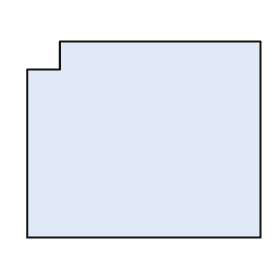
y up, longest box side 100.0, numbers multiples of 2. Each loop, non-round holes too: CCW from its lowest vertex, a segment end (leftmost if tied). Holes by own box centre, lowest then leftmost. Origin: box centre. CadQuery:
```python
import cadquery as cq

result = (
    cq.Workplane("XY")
    .moveTo(-50.0, -42.0)
    .lineTo(50.0, -42.0)
    .lineTo(50.0, 42.0)
    .lineTo(-36.0, 42.0)
    .lineTo(-36.0, 30.0)
    .lineTo(-50.0, 30.0)
    .close()
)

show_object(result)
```